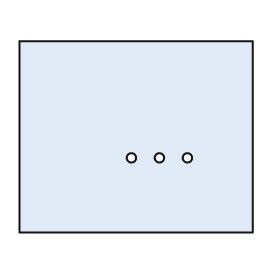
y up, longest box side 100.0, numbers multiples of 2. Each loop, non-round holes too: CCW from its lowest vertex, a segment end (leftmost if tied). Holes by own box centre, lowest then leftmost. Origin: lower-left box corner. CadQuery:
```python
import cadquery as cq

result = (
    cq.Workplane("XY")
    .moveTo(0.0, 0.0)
    .lineTo(100.0, 0.0)
    .lineTo(100.0, 82.0)
    .lineTo(0.0, 82.0)
    .close()
    .moveTo(48.0, 32.0)
    .circle(2.0)
    .moveTo(60.0, 32.0)
    .circle(2.0)
    .moveTo(72.0, 32.0)
    .circle(2.0)
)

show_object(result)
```